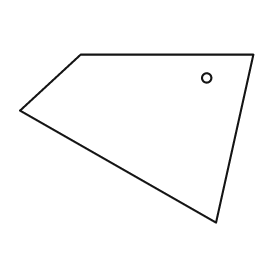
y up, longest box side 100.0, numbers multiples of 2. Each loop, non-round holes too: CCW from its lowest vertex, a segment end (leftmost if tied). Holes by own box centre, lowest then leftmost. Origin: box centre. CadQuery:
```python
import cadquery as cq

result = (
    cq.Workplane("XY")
    .moveTo(34.0, -36.0)
    .lineTo(50.0, 36.0)
    .lineTo(-24.0, 36.0)
    .lineTo(-50.0, 12.0)
    .close()
    .moveTo(30.0, 26.0)
    .circle(2.0)
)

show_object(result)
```